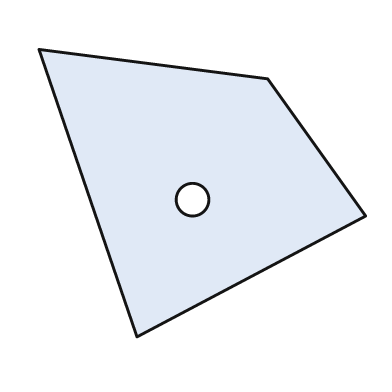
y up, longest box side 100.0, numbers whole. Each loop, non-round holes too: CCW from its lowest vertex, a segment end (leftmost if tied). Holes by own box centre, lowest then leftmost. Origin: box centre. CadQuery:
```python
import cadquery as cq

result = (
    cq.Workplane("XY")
    .moveTo(-20.0, -44.0)
    .lineTo(50.0, -7.0)
    .lineTo(20.0, 35.0)
    .lineTo(-50.0, 44.0)
    .close()
    .moveTo(-3.0, -2.0)
    .circle(5.0)
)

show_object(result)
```